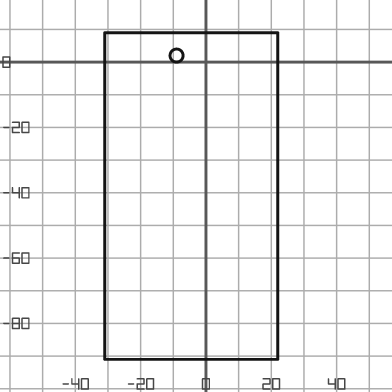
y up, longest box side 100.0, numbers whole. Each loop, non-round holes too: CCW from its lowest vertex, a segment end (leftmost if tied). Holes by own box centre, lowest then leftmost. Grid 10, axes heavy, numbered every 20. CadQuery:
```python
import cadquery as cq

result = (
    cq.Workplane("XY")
    .moveTo(-31.0, -91.0)
    .lineTo(22.0, -91.0)
    .lineTo(22.0, 9.0)
    .lineTo(-31.0, 9.0)
    .close()
    .moveTo(-9.0, 2.0)
    .circle(2.0)
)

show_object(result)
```